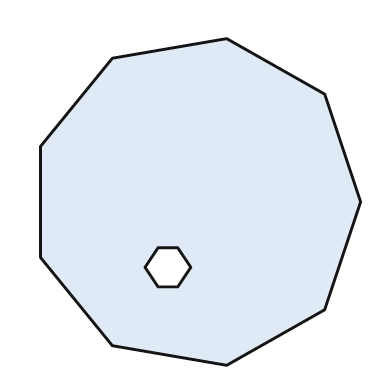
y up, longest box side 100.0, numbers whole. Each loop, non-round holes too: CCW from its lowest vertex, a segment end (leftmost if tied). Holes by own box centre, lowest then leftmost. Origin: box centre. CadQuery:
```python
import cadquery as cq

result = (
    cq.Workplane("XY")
    .moveTo(8.0, -50.0)
    .lineTo(38.0, -33.0)
    .lineTo(49.0, 0.0)
    .lineTo(38.0, 33.0)
    .lineTo(8.0, 50.0)
    .lineTo(-27.0, 44.0)
    .lineTo(-49.0, 17.0)
    .lineTo(-49.0, -17.0)
    .lineTo(-27.0, -44.0)
    .close()
    .moveTo(-13.0, -26.0)
    .lineTo(-7.0, -26.0)
    .lineTo(-3.0, -20.0)
    .lineTo(-7.0, -14.0)
    .lineTo(-13.0, -14.0)
    .lineTo(-17.0, -20.0)
    .close()
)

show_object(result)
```